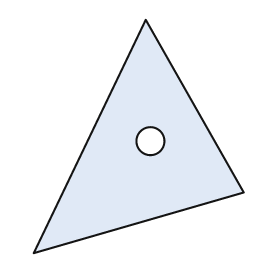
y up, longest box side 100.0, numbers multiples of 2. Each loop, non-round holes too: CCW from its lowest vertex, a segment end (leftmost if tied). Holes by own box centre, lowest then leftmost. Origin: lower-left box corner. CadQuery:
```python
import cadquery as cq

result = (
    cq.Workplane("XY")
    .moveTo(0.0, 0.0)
    .lineTo(90.0, 26.0)
    .lineTo(48.0, 100.0)
    .close()
    .moveTo(50.0, 48.0)
    .circle(6.0)
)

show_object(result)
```